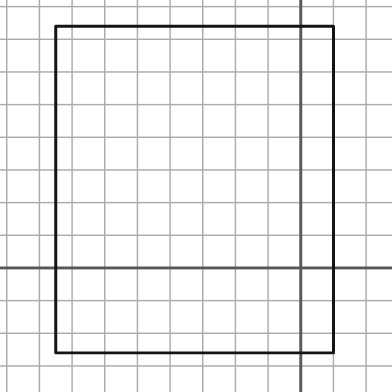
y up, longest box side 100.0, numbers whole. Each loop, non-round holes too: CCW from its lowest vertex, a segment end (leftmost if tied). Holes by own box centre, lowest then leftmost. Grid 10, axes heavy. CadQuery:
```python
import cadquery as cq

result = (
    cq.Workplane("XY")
    .moveTo(-75.0, -26.0)
    .lineTo(10.0, -26.0)
    .lineTo(10.0, 74.0)
    .lineTo(-75.0, 74.0)
    .close()
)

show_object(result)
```